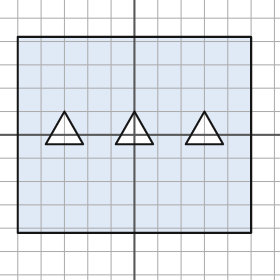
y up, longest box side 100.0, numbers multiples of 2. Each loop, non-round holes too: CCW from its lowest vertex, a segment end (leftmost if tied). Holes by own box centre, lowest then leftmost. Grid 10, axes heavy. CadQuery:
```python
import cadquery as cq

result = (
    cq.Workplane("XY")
    .moveTo(-50.0, -42.0)
    .lineTo(50.0, -42.0)
    .lineTo(50.0, 42.0)
    .lineTo(-50.0, 42.0)
    .close()
    .moveTo(-38.0, -4.0)
    .lineTo(-22.0, -4.0)
    .lineTo(-30.0, 10.0)
    .close()
    .moveTo(-8.0, -4.0)
    .lineTo(8.0, -4.0)
    .lineTo(0.0, 10.0)
    .close()
    .moveTo(22.0, -4.0)
    .lineTo(38.0, -4.0)
    .lineTo(30.0, 10.0)
    .close()
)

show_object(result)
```